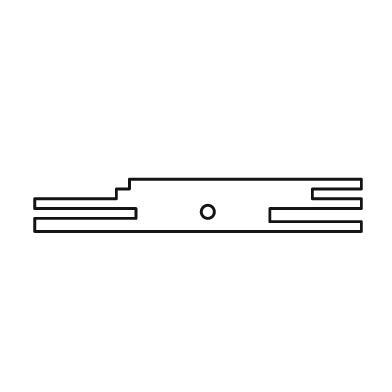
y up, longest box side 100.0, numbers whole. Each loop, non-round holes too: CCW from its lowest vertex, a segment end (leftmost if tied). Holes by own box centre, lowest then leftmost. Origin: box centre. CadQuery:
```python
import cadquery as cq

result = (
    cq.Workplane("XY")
    .moveTo(-50.0, -8.0)
    .lineTo(50.0, -8.0)
    .lineTo(50.0, -5.0)
    .lineTo(22.0, -5.0)
    .lineTo(22.0, -1.0)
    .lineTo(50.0, -1.0)
    .lineTo(50.0, 2.0)
    .lineTo(35.0, 2.0)
    .lineTo(35.0, 5.0)
    .lineTo(50.0, 5.0)
    .lineTo(50.0, 8.0)
    .lineTo(-21.0, 8.0)
    .lineTo(-21.0, 5.0)
    .lineTo(-25.0, 5.0)
    .lineTo(-25.0, 2.0)
    .lineTo(-50.0, 2.0)
    .lineTo(-50.0, -1.0)
    .lineTo(-19.0, -1.0)
    .lineTo(-19.0, -4.0)
    .lineTo(-50.0, -4.0)
    .close()
    .moveTo(3.0, -2.0)
    .circle(2.0)
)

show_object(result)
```